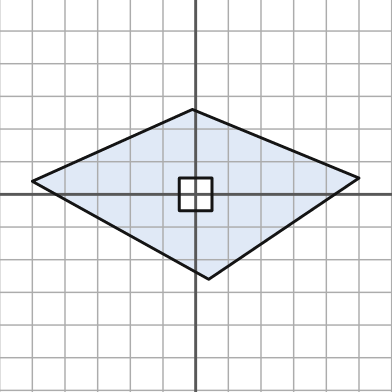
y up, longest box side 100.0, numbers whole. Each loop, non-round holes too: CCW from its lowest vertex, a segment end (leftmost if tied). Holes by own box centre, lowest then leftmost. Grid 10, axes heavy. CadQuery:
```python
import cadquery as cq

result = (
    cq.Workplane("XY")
    .moveTo(4.0, -26.0)
    .lineTo(50.0, 5.0)
    .lineTo(-1.0, 26.0)
    .lineTo(-50.0, 4.0)
    .close()
    .moveTo(-5.0, -5.0)
    .lineTo(5.0, -5.0)
    .lineTo(5.0, 5.0)
    .lineTo(-5.0, 5.0)
    .close()
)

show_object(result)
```